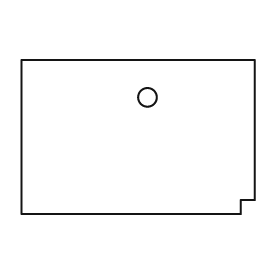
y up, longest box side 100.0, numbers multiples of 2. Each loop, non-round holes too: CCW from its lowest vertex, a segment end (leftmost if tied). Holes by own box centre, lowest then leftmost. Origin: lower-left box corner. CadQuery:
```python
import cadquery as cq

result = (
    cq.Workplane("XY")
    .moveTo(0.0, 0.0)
    .lineTo(94.0, 0.0)
    .lineTo(94.0, 6.0)
    .lineTo(100.0, 6.0)
    .lineTo(100.0, 66.0)
    .lineTo(0.0, 66.0)
    .close()
    .moveTo(54.0, 50.0)
    .circle(4.0)
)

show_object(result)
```